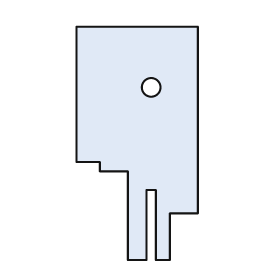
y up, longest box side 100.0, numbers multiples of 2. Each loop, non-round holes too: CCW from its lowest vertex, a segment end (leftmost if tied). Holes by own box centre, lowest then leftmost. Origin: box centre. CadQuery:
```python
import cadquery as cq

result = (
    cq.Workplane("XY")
    .moveTo(-4.0, -50.0)
    .lineTo(4.0, -50.0)
    .lineTo(4.0, -20.0)
    .lineTo(8.0, -20.0)
    .lineTo(8.0, -50.0)
    .lineTo(14.0, -50.0)
    .lineTo(14.0, -30.0)
    .lineTo(26.0, -30.0)
    .lineTo(26.0, 50.0)
    .lineTo(-26.0, 50.0)
    .lineTo(-26.0, -8.0)
    .lineTo(-16.0, -8.0)
    .lineTo(-16.0, -12.0)
    .lineTo(-4.0, -12.0)
    .close()
    .moveTo(6.0, 24.0)
    .circle(4.0)
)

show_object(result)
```